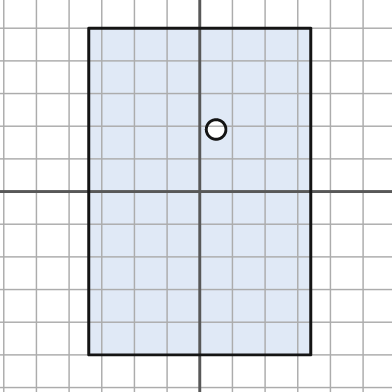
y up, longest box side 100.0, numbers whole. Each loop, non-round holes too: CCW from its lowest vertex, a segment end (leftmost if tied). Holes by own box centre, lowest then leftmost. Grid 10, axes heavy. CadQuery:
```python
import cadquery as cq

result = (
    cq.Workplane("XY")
    .moveTo(-34.0, -50.0)
    .lineTo(34.0, -50.0)
    .lineTo(34.0, 50.0)
    .lineTo(-34.0, 50.0)
    .close()
    .moveTo(5.0, 19.0)
    .circle(3.0)
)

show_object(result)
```